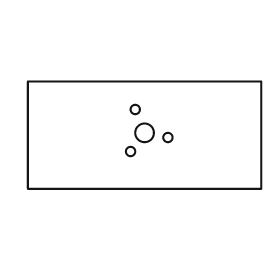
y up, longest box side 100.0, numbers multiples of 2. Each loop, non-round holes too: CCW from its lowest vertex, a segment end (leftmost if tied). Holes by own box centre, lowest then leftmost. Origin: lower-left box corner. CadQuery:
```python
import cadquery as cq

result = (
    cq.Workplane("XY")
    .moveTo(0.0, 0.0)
    .lineTo(100.0, 0.0)
    .lineTo(100.0, 46.0)
    .lineTo(0.0, 46.0)
    .close()
    .moveTo(44.0, 16.0)
    .circle(2.0)
    .moveTo(60.0, 22.0)
    .circle(2.0)
    .moveTo(50.0, 24.0)
    .circle(4.0)
    .moveTo(46.0, 34.0)
    .circle(2.0)
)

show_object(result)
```